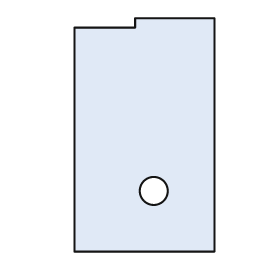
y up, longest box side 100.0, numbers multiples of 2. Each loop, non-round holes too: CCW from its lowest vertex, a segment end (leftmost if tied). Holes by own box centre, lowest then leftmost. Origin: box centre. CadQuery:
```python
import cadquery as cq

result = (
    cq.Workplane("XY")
    .moveTo(-30.0, -50.0)
    .lineTo(30.0, -50.0)
    .lineTo(30.0, 50.0)
    .lineTo(-4.0, 50.0)
    .lineTo(-4.0, 46.0)
    .lineTo(-30.0, 46.0)
    .close()
    .moveTo(4.0, -24.0)
    .circle(6.0)
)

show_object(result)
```